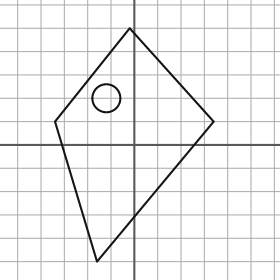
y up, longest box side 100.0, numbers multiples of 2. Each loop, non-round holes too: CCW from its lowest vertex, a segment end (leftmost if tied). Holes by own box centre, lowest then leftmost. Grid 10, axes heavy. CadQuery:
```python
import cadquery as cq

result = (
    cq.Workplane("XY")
    .moveTo(-16.0, -50.0)
    .lineTo(34.0, 10.0)
    .lineTo(-2.0, 50.0)
    .lineTo(-34.0, 10.0)
    .close()
    .moveTo(-12.0, 20.0)
    .circle(6.0)
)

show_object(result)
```